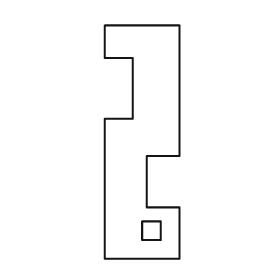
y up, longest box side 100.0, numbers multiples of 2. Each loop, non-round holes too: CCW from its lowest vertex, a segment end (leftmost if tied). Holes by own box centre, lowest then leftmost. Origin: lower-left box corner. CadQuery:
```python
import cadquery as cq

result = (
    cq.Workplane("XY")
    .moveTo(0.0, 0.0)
    .lineTo(32.0, 0.0)
    .lineTo(32.0, 22.0)
    .lineTo(18.0, 22.0)
    .lineTo(18.0, 44.0)
    .lineTo(32.0, 44.0)
    .lineTo(32.0, 100.0)
    .lineTo(0.0, 100.0)
    .lineTo(0.0, 86.0)
    .lineTo(12.0, 86.0)
    .lineTo(12.0, 60.0)
    .lineTo(0.0, 60.0)
    .close()
    .moveTo(16.0, 8.0)
    .lineTo(24.0, 8.0)
    .lineTo(24.0, 16.0)
    .lineTo(16.0, 16.0)
    .close()
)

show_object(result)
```